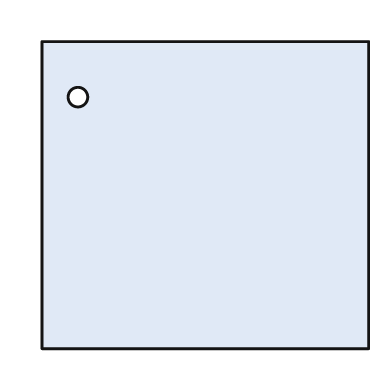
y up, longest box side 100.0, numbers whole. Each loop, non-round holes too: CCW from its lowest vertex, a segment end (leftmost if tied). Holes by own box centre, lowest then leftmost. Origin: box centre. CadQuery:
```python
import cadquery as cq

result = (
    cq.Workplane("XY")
    .moveTo(-50.0, -47.0)
    .lineTo(50.0, -47.0)
    .lineTo(50.0, 47.0)
    .lineTo(-50.0, 47.0)
    .close()
    .moveTo(-39.0, 30.0)
    .circle(3.0)
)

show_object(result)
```